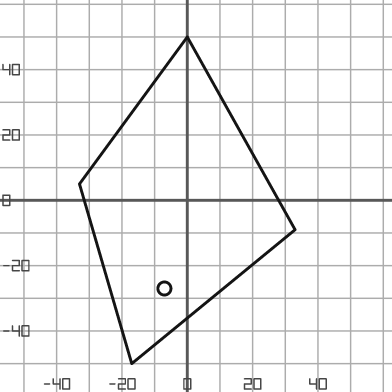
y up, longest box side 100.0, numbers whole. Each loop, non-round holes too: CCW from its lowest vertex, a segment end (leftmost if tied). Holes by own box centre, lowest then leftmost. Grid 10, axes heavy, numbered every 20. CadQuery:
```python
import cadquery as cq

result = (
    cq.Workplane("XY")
    .moveTo(-17.0, -50.0)
    .lineTo(33.0, -9.0)
    .lineTo(0.0, 50.0)
    .lineTo(-33.0, 5.0)
    .close()
    .moveTo(-7.0, -27.0)
    .circle(2.0)
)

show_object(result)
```